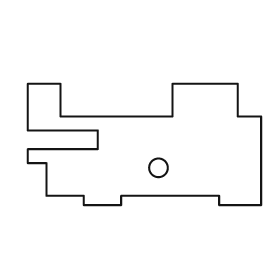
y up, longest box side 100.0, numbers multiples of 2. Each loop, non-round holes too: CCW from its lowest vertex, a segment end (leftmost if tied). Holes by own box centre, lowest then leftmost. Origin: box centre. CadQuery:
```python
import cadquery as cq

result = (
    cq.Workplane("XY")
    .moveTo(-26.0, -26.0)
    .lineTo(-10.0, -26.0)
    .lineTo(-10.0, -22.0)
    .lineTo(32.0, -22.0)
    .lineTo(32.0, -26.0)
    .lineTo(50.0, -26.0)
    .lineTo(50.0, 12.0)
    .lineTo(40.0, 12.0)
    .lineTo(40.0, 26.0)
    .lineTo(12.0, 26.0)
    .lineTo(12.0, 12.0)
    .lineTo(-36.0, 12.0)
    .lineTo(-36.0, 26.0)
    .lineTo(-50.0, 26.0)
    .lineTo(-50.0, 6.0)
    .lineTo(-20.0, 6.0)
    .lineTo(-20.0, -2.0)
    .lineTo(-50.0, -2.0)
    .lineTo(-50.0, -8.0)
    .lineTo(-42.0, -8.0)
    .lineTo(-42.0, -22.0)
    .lineTo(-26.0, -22.0)
    .close()
    .moveTo(6.0, -10.0)
    .circle(4.0)
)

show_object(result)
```